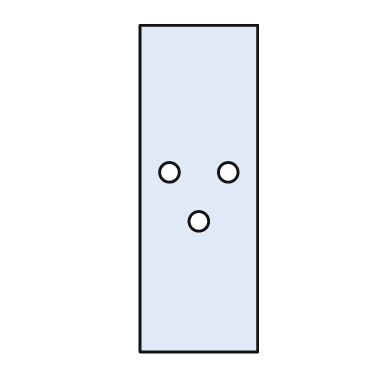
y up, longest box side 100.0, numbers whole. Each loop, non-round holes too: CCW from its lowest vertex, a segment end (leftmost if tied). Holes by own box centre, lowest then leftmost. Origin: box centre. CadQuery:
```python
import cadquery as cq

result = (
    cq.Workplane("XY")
    .moveTo(-18.0, -50.0)
    .lineTo(18.0, -50.0)
    .lineTo(18.0, 50.0)
    .lineTo(-18.0, 50.0)
    .close()
    .moveTo(0.0, -10.0)
    .circle(3.0)
    .moveTo(-9.0, 5.0)
    .circle(3.0)
    .moveTo(9.0, 5.0)
    .circle(3.0)
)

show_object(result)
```